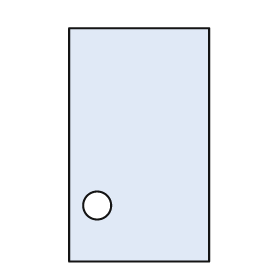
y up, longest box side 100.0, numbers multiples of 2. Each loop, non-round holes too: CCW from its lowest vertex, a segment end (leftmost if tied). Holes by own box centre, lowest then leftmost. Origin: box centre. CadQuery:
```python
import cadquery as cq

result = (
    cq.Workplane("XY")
    .moveTo(-30.0, -50.0)
    .lineTo(30.0, -50.0)
    .lineTo(30.0, 50.0)
    .lineTo(-30.0, 50.0)
    .close()
    .moveTo(-18.0, -26.0)
    .circle(6.0)
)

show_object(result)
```